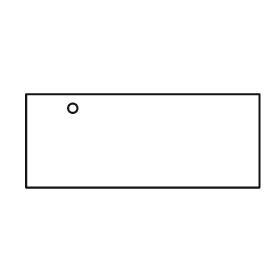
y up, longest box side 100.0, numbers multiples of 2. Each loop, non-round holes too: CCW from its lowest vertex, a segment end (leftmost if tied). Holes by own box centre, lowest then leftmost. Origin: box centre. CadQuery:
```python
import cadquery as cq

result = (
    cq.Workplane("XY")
    .moveTo(-50.0, -20.0)
    .lineTo(50.0, -20.0)
    .lineTo(50.0, 20.0)
    .lineTo(-50.0, 20.0)
    .close()
    .moveTo(-30.0, 14.0)
    .circle(2.0)
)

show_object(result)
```